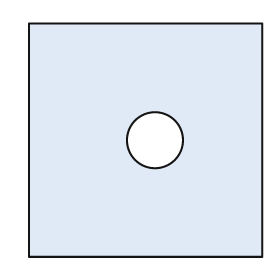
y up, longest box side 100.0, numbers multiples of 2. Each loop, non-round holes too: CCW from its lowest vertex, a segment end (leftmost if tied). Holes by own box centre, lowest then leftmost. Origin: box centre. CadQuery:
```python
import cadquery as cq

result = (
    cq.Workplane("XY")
    .moveTo(-50.0, -50.0)
    .lineTo(50.0, -50.0)
    .lineTo(50.0, 50.0)
    .lineTo(-50.0, 50.0)
    .close()
    .moveTo(4.0, 0.0)
    .circle(12.0)
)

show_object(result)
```